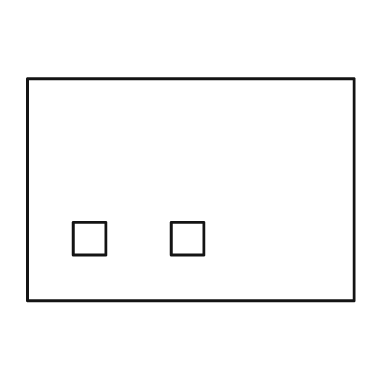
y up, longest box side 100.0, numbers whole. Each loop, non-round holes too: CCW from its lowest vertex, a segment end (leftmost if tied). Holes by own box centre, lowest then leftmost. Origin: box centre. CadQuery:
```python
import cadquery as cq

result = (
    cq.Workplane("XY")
    .moveTo(-50.0, -34.0)
    .lineTo(50.0, -34.0)
    .lineTo(50.0, 34.0)
    .lineTo(-50.0, 34.0)
    .close()
    .moveTo(-36.0, -20.0)
    .lineTo(-26.0, -20.0)
    .lineTo(-26.0, -10.0)
    .lineTo(-36.0, -10.0)
    .close()
    .moveTo(-6.0, -20.0)
    .lineTo(4.0, -20.0)
    .lineTo(4.0, -10.0)
    .lineTo(-6.0, -10.0)
    .close()
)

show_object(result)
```